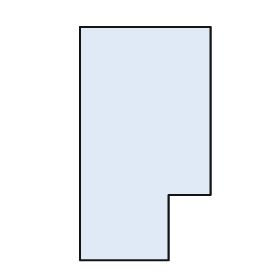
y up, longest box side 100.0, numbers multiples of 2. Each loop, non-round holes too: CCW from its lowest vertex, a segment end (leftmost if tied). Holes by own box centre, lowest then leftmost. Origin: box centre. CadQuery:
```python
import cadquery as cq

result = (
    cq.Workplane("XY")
    .moveTo(-28.0, -50.0)
    .lineTo(10.0, -50.0)
    .lineTo(10.0, -22.0)
    .lineTo(28.0, -22.0)
    .lineTo(28.0, 50.0)
    .lineTo(-28.0, 50.0)
    .close()
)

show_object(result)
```